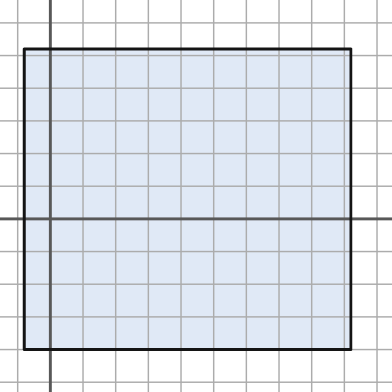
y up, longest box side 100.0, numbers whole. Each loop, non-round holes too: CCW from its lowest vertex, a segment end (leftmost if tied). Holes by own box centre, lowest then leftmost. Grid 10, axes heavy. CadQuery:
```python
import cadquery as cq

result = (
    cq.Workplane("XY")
    .moveTo(-8.0, -40.0)
    .lineTo(92.0, -40.0)
    .lineTo(92.0, 52.0)
    .lineTo(-8.0, 52.0)
    .close()
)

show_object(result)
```